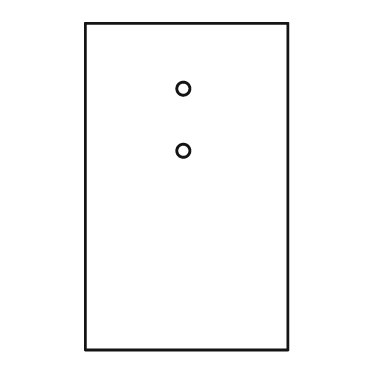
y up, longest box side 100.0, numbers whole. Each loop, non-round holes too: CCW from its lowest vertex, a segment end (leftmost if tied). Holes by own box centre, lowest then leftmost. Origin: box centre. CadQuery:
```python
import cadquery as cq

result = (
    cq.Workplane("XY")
    .moveTo(-31.0, -50.0)
    .lineTo(31.0, -50.0)
    .lineTo(31.0, 50.0)
    .lineTo(-31.0, 50.0)
    .close()
    .moveTo(-1.0, 11.0)
    .circle(2.0)
    .moveTo(-1.0, 30.0)
    .circle(2.0)
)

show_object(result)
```